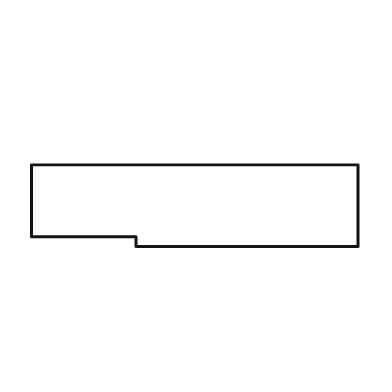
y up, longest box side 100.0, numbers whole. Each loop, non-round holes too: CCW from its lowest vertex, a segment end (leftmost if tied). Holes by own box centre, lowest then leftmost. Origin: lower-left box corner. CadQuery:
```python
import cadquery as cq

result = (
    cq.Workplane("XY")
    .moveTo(32.0, 0.0)
    .lineTo(100.0, 0.0)
    .lineTo(100.0, 25.0)
    .lineTo(0.0, 25.0)
    .lineTo(0.0, 3.0)
    .lineTo(32.0, 3.0)
    .close()
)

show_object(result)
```